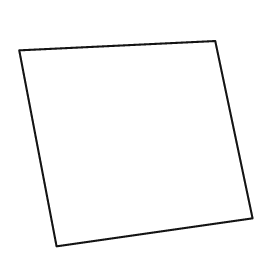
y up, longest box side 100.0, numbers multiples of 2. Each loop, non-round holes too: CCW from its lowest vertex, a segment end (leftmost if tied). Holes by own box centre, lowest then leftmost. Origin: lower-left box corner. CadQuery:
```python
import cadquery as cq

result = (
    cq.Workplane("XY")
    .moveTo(16.0, 0.0)
    .lineTo(100.0, 12.0)
    .lineTo(84.0, 88.0)
    .lineTo(0.0, 84.0)
    .close()
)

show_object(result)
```